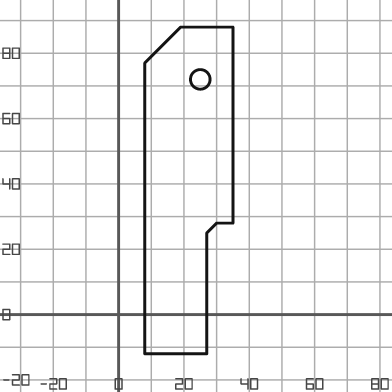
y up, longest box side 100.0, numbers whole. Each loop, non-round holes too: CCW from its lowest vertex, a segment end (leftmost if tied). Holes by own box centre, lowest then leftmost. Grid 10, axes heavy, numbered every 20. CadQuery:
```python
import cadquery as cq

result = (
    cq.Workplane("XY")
    .moveTo(8.0, -12.0)
    .lineTo(27.0, -12.0)
    .lineTo(27.0, 25.0)
    .lineTo(30.0, 28.0)
    .lineTo(35.0, 28.0)
    .lineTo(35.0, 88.0)
    .lineTo(19.0, 88.0)
    .lineTo(8.0, 77.0)
    .close()
    .moveTo(25.0, 72.0)
    .circle(3.0)
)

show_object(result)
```